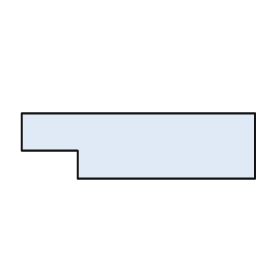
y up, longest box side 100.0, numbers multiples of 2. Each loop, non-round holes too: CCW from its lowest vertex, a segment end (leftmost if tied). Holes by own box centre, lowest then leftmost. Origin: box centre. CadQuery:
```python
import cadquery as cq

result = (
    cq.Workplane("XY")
    .moveTo(-26.0, -14.0)
    .lineTo(50.0, -14.0)
    .lineTo(50.0, 14.0)
    .lineTo(-50.0, 14.0)
    .lineTo(-50.0, -2.0)
    .lineTo(-26.0, -2.0)
    .close()
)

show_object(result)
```